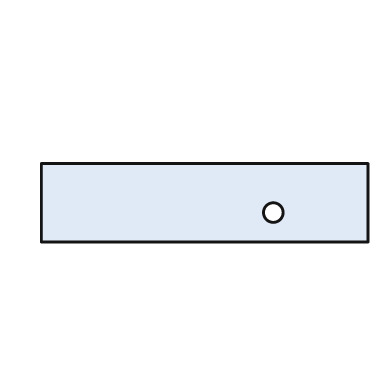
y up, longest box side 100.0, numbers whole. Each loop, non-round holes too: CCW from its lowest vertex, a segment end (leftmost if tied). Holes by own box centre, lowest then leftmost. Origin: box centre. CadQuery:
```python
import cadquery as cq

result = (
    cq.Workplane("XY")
    .moveTo(-50.0, -12.0)
    .lineTo(50.0, -12.0)
    .lineTo(50.0, 12.0)
    .lineTo(-50.0, 12.0)
    .close()
    .moveTo(21.0, -3.0)
    .circle(3.0)
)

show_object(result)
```